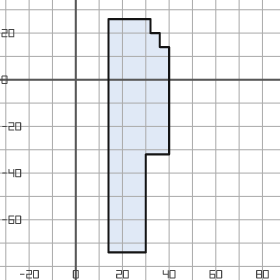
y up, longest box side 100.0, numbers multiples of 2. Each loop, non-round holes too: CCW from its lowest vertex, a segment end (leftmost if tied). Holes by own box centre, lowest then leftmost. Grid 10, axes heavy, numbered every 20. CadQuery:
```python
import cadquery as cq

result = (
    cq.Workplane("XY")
    .moveTo(14.0, -74.0)
    .lineTo(30.0, -74.0)
    .lineTo(30.0, -32.0)
    .lineTo(40.0, -32.0)
    .lineTo(40.0, 14.0)
    .lineTo(36.0, 14.0)
    .lineTo(36.0, 20.0)
    .lineTo(32.0, 20.0)
    .lineTo(32.0, 26.0)
    .lineTo(14.0, 26.0)
    .close()
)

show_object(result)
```